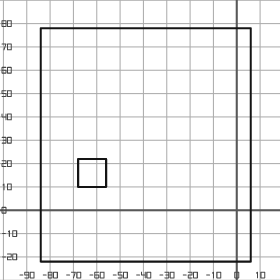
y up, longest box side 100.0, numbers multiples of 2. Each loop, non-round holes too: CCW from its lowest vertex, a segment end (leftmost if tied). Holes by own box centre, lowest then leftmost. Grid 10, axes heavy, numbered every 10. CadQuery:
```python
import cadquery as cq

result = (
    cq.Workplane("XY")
    .moveTo(-84.0, -22.0)
    .lineTo(6.0, -22.0)
    .lineTo(6.0, 78.0)
    .lineTo(-84.0, 78.0)
    .close()
    .moveTo(-68.0, 10.0)
    .lineTo(-56.0, 10.0)
    .lineTo(-56.0, 22.0)
    .lineTo(-68.0, 22.0)
    .close()
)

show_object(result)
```